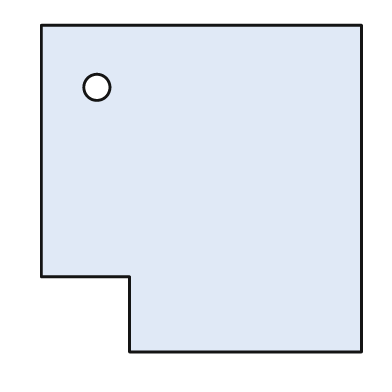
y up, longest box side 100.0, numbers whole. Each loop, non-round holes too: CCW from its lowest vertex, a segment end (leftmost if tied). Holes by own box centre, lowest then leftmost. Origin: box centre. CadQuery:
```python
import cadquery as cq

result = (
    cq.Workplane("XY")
    .moveTo(-22.0, -50.0)
    .lineTo(49.0, -50.0)
    .lineTo(49.0, 50.0)
    .lineTo(-49.0, 50.0)
    .lineTo(-49.0, -27.0)
    .lineTo(-22.0, -27.0)
    .close()
    .moveTo(-32.0, 31.0)
    .circle(4.0)
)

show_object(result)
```